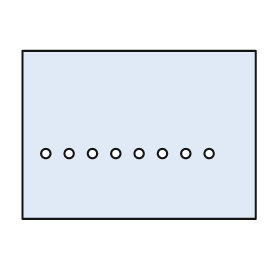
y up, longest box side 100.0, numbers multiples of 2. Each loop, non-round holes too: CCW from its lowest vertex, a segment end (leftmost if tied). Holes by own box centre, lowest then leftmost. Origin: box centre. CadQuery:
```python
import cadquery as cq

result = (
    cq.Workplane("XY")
    .moveTo(-50.0, -36.0)
    .lineTo(50.0, -36.0)
    .lineTo(50.0, 36.0)
    .lineTo(-50.0, 36.0)
    .close()
    .moveTo(-40.0, -8.0)
    .circle(2.0)
    .moveTo(-30.0, -8.0)
    .circle(2.0)
    .moveTo(-20.0, -8.0)
    .circle(2.0)
    .moveTo(-10.0, -8.0)
    .circle(2.0)
    .moveTo(0.0, -8.0)
    .circle(2.0)
    .moveTo(10.0, -8.0)
    .circle(2.0)
    .moveTo(20.0, -8.0)
    .circle(2.0)
    .moveTo(30.0, -8.0)
    .circle(2.0)
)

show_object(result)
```